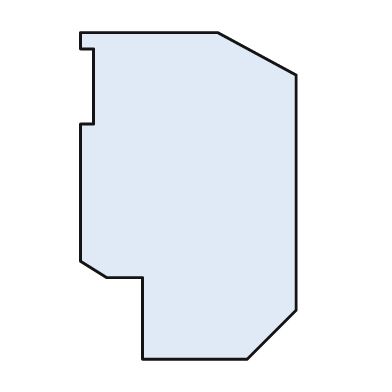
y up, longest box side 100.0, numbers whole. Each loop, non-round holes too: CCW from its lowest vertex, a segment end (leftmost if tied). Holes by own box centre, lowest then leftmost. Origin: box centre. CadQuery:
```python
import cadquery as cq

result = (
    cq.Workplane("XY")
    .moveTo(-14.0, -50.0)
    .lineTo(18.0, -50.0)
    .lineTo(33.0, -35.0)
    .lineTo(33.0, 37.0)
    .lineTo(9.0, 50.0)
    .lineTo(-33.0, 50.0)
    .lineTo(-33.0, 45.0)
    .lineTo(-29.0, 45.0)
    .lineTo(-29.0, 22.0)
    .lineTo(-33.0, 22.0)
    .lineTo(-33.0, -20.0)
    .lineTo(-25.0, -25.0)
    .lineTo(-14.0, -25.0)
    .close()
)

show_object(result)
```